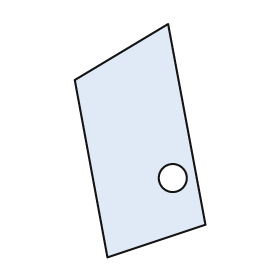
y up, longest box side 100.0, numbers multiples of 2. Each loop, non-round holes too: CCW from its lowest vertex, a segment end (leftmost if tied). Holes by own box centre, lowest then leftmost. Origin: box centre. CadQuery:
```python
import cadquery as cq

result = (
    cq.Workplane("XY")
    .moveTo(-14.0, -50.0)
    .lineTo(28.0, -36.0)
    .lineTo(12.0, 50.0)
    .lineTo(-28.0, 26.0)
    .close()
    .moveTo(14.0, -16.0)
    .circle(6.0)
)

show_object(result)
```